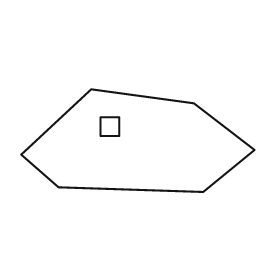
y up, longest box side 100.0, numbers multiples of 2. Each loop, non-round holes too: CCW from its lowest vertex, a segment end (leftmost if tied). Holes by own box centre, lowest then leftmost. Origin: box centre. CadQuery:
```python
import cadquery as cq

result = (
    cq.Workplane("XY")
    .moveTo(28.0, -22.0)
    .lineTo(50.0, -4.0)
    .lineTo(24.0, 16.0)
    .lineTo(-20.0, 22.0)
    .lineTo(-50.0, -6.0)
    .lineTo(-34.0, -20.0)
    .close()
    .moveTo(-16.0, 2.0)
    .lineTo(-8.0, 2.0)
    .lineTo(-8.0, 10.0)
    .lineTo(-16.0, 10.0)
    .close()
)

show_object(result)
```